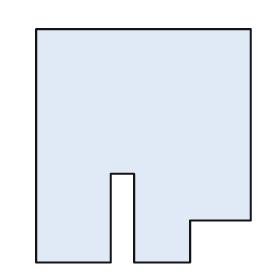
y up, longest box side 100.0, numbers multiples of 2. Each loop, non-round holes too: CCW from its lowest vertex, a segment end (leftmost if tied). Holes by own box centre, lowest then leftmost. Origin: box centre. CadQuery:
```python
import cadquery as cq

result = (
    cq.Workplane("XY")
    .moveTo(-46.0, -50.0)
    .lineTo(-14.0, -50.0)
    .lineTo(-14.0, -12.0)
    .lineTo(-4.0, -12.0)
    .lineTo(-4.0, -50.0)
    .lineTo(20.0, -50.0)
    .lineTo(20.0, -32.0)
    .lineTo(46.0, -32.0)
    .lineTo(46.0, 50.0)
    .lineTo(-46.0, 50.0)
    .close()
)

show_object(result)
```